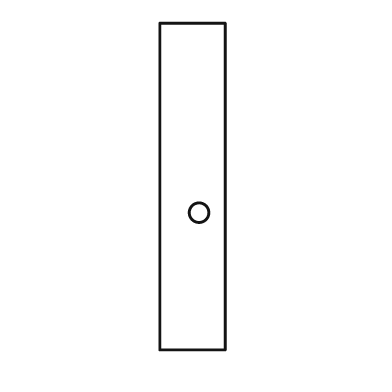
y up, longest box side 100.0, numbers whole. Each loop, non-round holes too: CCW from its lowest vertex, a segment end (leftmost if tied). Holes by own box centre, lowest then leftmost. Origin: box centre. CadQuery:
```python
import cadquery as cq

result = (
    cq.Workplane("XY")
    .moveTo(-10.0, -50.0)
    .lineTo(10.0, -50.0)
    .lineTo(10.0, 50.0)
    .lineTo(-10.0, 50.0)
    .close()
    .moveTo(2.0, -8.0)
    .circle(3.0)
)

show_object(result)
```